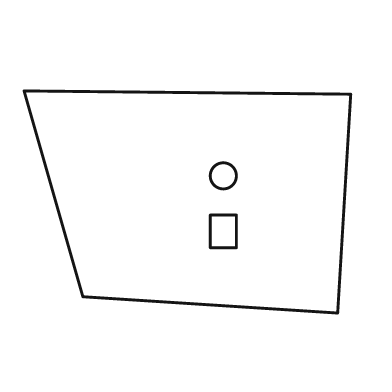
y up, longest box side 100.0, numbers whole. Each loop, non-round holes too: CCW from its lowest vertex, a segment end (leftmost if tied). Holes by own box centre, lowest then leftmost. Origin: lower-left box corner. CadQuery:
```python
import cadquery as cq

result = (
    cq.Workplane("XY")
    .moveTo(96.0, 0.0)
    .lineTo(100.0, 67.0)
    .lineTo(0.0, 68.0)
    .lineTo(18.0, 5.0)
    .close()
    .moveTo(57.0, 20.0)
    .lineTo(65.0, 20.0)
    .lineTo(65.0, 30.0)
    .lineTo(57.0, 30.0)
    .close()
    .moveTo(61.0, 42.0)
    .circle(4.0)
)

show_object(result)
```